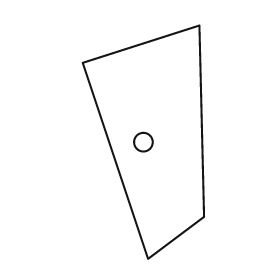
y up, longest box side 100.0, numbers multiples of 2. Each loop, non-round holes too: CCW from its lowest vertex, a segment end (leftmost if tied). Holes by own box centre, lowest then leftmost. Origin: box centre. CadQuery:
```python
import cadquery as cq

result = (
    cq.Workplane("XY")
    .moveTo(2.0, -50.0)
    .lineTo(26.0, -32.0)
    .lineTo(24.0, 50.0)
    .lineTo(-26.0, 34.0)
    .close()
    .moveTo(0.0, 0.0)
    .circle(4.0)
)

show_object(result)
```